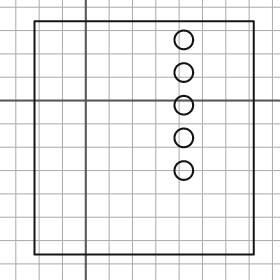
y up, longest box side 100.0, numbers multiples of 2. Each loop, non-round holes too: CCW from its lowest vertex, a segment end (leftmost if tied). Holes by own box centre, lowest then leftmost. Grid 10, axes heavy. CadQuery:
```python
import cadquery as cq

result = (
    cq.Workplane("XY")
    .moveTo(-22.0, -66.0)
    .lineTo(72.0, -66.0)
    .lineTo(72.0, 34.0)
    .lineTo(-22.0, 34.0)
    .close()
    .moveTo(42.0, -30.0)
    .circle(4.0)
    .moveTo(42.0, -16.0)
    .circle(4.0)
    .moveTo(42.0, -2.0)
    .circle(4.0)
    .moveTo(42.0, 12.0)
    .circle(4.0)
    .moveTo(42.0, 26.0)
    .circle(4.0)
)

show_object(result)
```